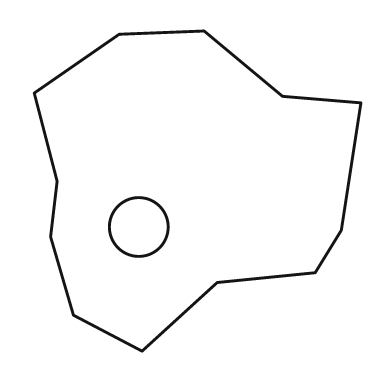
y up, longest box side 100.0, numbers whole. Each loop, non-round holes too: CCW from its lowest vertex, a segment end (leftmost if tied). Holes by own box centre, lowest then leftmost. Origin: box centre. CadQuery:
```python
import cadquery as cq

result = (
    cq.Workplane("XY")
    .moveTo(-17.0, -49.0)
    .lineTo(6.0, -28.0)
    .lineTo(36.0, -25.0)
    .lineTo(44.0, -12.0)
    .lineTo(50.0, 27.0)
    .lineTo(26.0, 29.0)
    .lineTo(2.0, 49.0)
    .lineTo(-24.0, 48.0)
    .lineTo(-50.0, 30.0)
    .lineTo(-43.0, 3.0)
    .lineTo(-45.0, -14.0)
    .lineTo(-38.0, -38.0)
    .close()
    .moveTo(-18.0, -11.0)
    .circle(9.0)
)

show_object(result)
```